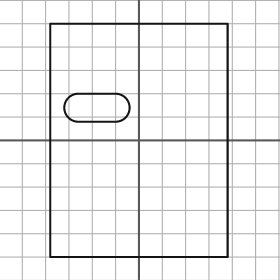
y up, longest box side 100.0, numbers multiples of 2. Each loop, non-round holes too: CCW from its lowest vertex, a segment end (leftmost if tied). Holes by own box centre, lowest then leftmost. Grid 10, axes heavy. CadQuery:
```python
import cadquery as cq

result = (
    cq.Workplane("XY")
    .moveTo(-38.0, -50.0)
    .lineTo(38.0, -50.0)
    .lineTo(38.0, 50.0)
    .lineTo(-38.0, 50.0)
    .close()
    .moveTo(-26.0, 8.0)
    .lineTo(-10.0, 8.0)
    .threePointArc((-4.0, 14.0), (-10.0, 20.0))
    .lineTo(-26.0, 20.0)
    .threePointArc((-32.0, 14.0), (-26.0, 8.0))
    .close()
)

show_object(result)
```